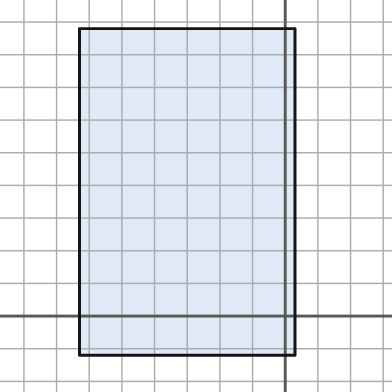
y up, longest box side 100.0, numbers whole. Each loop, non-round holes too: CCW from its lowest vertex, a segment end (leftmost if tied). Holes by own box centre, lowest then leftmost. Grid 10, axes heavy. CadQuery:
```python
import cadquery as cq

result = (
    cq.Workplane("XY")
    .moveTo(-63.0, -12.0)
    .lineTo(3.0, -12.0)
    .lineTo(3.0, 88.0)
    .lineTo(-63.0, 88.0)
    .close()
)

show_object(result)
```